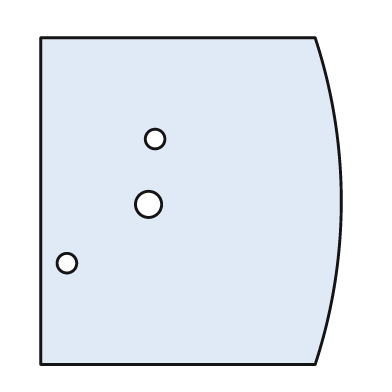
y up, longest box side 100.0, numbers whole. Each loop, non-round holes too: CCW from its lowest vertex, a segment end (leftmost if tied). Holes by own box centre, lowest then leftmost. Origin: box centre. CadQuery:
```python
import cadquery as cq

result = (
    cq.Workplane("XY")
    .moveTo(-46.0, -50.0)
    .lineTo(38.0, -50.0)
    .threePointArc((46.0, 0.0), (38.0, 50.0))
    .lineTo(-46.0, 50.0)
    .close()
    .moveTo(-38.0, -19.0)
    .circle(3.0)
    .moveTo(-13.0, -1.0)
    .circle(4.0)
    .moveTo(-11.0, 19.0)
    .circle(3.0)
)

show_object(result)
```